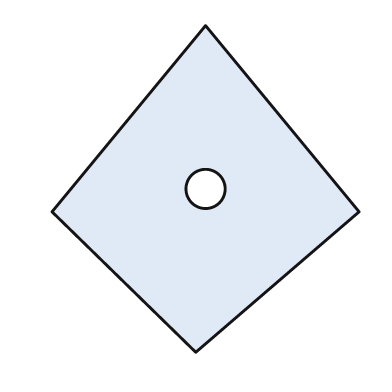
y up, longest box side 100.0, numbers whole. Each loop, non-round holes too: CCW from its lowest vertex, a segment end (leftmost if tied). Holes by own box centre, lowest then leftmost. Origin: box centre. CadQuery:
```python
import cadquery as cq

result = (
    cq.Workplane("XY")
    .moveTo(-3.0, -50.0)
    .lineTo(47.0, -7.0)
    .lineTo(0.0, 50.0)
    .lineTo(-47.0, -7.0)
    .close()
    .moveTo(0.0, 0.0)
    .circle(6.0)
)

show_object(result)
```